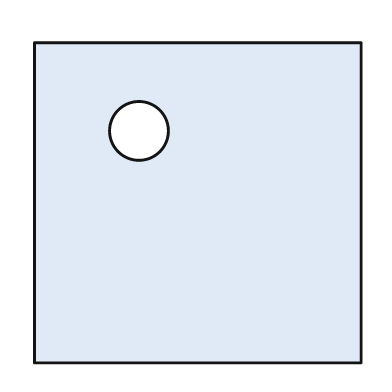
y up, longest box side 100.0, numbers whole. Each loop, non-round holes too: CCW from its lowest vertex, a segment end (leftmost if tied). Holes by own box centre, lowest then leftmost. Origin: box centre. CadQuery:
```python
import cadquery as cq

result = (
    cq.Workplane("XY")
    .moveTo(-50.0, -49.0)
    .lineTo(50.0, -49.0)
    .lineTo(50.0, 49.0)
    .lineTo(-50.0, 49.0)
    .close()
    .moveTo(-18.0, 22.0)
    .circle(9.0)
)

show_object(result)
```